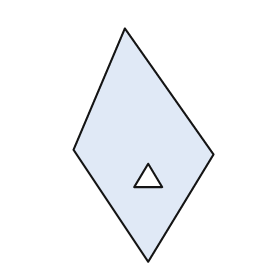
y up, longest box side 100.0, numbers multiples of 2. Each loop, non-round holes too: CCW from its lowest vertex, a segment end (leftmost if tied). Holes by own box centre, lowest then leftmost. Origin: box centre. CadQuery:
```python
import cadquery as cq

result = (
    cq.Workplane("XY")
    .moveTo(2.0, -50.0)
    .lineTo(30.0, -4.0)
    .lineTo(-8.0, 50.0)
    .lineTo(-30.0, -2.0)
    .close()
    .moveTo(-4.0, -18.0)
    .lineTo(8.0, -18.0)
    .lineTo(2.0, -8.0)
    .close()
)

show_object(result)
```